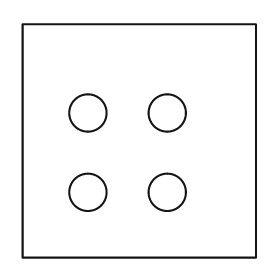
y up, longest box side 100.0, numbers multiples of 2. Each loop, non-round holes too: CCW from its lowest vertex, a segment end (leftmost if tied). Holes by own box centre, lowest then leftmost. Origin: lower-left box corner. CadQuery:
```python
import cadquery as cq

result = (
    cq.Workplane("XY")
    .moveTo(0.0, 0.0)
    .lineTo(100.0, 0.0)
    .lineTo(100.0, 100.0)
    .lineTo(0.0, 100.0)
    .close()
    .moveTo(28.0, 28.0)
    .circle(8.0)
    .moveTo(62.0, 28.0)
    .circle(8.0)
    .moveTo(28.0, 62.0)
    .circle(8.0)
    .moveTo(62.0, 62.0)
    .circle(8.0)
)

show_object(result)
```